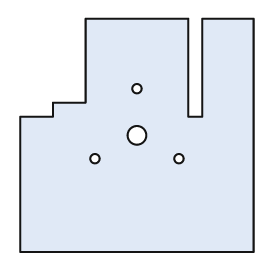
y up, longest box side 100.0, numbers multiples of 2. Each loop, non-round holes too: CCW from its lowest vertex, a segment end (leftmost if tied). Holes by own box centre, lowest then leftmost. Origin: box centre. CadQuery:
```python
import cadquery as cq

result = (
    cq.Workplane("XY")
    .moveTo(-50.0, -50.0)
    .lineTo(50.0, -50.0)
    .lineTo(50.0, 50.0)
    .lineTo(28.0, 50.0)
    .lineTo(28.0, 8.0)
    .lineTo(22.0, 8.0)
    .lineTo(22.0, 50.0)
    .lineTo(-22.0, 50.0)
    .lineTo(-22.0, 14.0)
    .lineTo(-36.0, 14.0)
    .lineTo(-36.0, 8.0)
    .lineTo(-50.0, 8.0)
    .close()
    .moveTo(-18.0, -10.0)
    .circle(2.0)
    .moveTo(18.0, -10.0)
    .circle(2.0)
    .moveTo(0.0, 0.0)
    .circle(4.0)
    .moveTo(0.0, 20.0)
    .circle(2.0)
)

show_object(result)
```